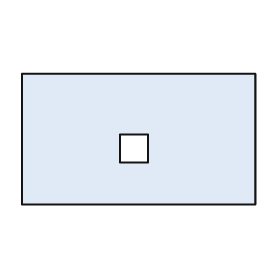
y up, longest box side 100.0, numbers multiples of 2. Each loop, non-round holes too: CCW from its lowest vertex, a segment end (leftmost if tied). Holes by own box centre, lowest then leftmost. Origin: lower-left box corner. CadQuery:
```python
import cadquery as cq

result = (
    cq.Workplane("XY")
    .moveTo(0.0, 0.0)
    .lineTo(100.0, 0.0)
    .lineTo(100.0, 56.0)
    .lineTo(0.0, 56.0)
    .close()
    .moveTo(42.0, 18.0)
    .lineTo(54.0, 18.0)
    .lineTo(54.0, 30.0)
    .lineTo(42.0, 30.0)
    .close()
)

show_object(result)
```